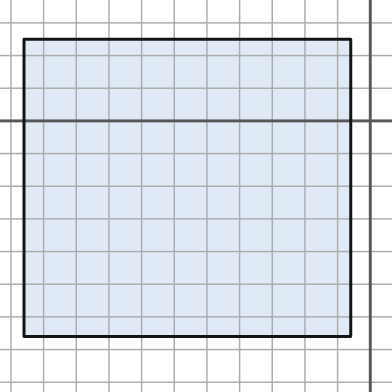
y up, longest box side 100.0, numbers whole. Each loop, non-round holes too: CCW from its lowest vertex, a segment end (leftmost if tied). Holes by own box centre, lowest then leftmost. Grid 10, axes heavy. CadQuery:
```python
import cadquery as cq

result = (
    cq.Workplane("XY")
    .moveTo(-106.0, -66.0)
    .lineTo(-6.0, -66.0)
    .lineTo(-6.0, 25.0)
    .lineTo(-106.0, 25.0)
    .close()
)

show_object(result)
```